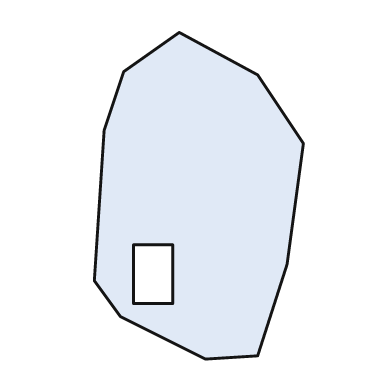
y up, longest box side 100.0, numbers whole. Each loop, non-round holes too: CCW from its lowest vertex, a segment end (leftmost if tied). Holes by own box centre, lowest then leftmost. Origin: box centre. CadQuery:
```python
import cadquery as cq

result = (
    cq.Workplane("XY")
    .moveTo(2.0, -50.0)
    .lineTo(18.0, -49.0)
    .lineTo(27.0, -21.0)
    .lineTo(32.0, 16.0)
    .lineTo(18.0, 37.0)
    .lineTo(-6.0, 50.0)
    .lineTo(-23.0, 38.0)
    .lineTo(-29.0, 20.0)
    .lineTo(-32.0, -26.0)
    .lineTo(-24.0, -37.0)
    .close()
    .moveTo(-20.0, -33.0)
    .lineTo(-8.0, -33.0)
    .lineTo(-8.0, -15.0)
    .lineTo(-20.0, -15.0)
    .close()
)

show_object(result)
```